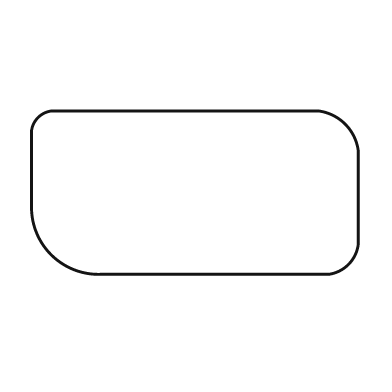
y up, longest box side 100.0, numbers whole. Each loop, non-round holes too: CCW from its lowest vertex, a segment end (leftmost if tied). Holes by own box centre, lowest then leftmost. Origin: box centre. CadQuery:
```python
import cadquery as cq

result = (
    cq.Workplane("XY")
    .moveTo(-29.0, -25.0)
    .lineTo(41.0, -25.0)
    .threePointArc((47.0, -22.0), (50.0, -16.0))
    .lineTo(50.0, 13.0)
    .threePointArc((46.0, 21.0), (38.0, 25.0))
    .lineTo(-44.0, 25.0)
    .threePointArc((-48.0, 23.0), (-50.0, 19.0))
    .lineTo(-50.0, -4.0)
    .threePointArc((-44.0, -19.0), (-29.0, -25.0))
    .close()
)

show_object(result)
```